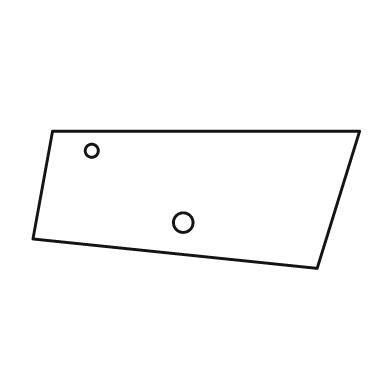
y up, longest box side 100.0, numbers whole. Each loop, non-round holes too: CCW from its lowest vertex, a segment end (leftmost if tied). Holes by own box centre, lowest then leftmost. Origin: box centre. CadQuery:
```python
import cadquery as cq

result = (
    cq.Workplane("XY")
    .moveTo(37.0, -21.0)
    .lineTo(50.0, 21.0)
    .lineTo(-44.0, 21.0)
    .lineTo(-50.0, -12.0)
    .close()
    .moveTo(-4.0, -7.0)
    .circle(3.0)
    .moveTo(-32.0, 15.0)
    .circle(2.0)
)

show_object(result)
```